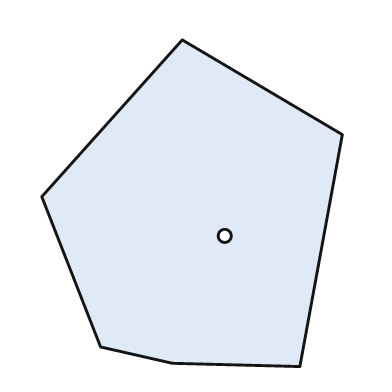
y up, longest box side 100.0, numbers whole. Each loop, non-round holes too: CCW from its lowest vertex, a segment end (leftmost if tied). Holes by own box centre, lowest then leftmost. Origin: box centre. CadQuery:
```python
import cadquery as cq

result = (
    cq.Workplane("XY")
    .moveTo(33.0, -50.0)
    .lineTo(46.0, 21.0)
    .lineTo(-3.0, 50.0)
    .lineTo(-46.0, 2.0)
    .lineTo(-28.0, -44.0)
    .lineTo(-6.0, -49.0)
    .close()
    .moveTo(10.0, -10.0)
    .circle(2.0)
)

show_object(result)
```